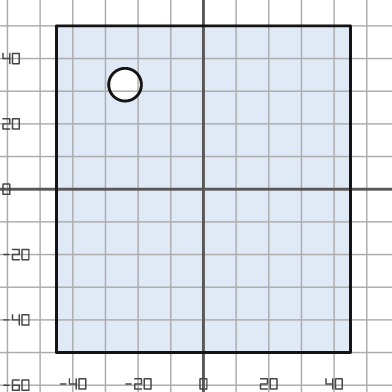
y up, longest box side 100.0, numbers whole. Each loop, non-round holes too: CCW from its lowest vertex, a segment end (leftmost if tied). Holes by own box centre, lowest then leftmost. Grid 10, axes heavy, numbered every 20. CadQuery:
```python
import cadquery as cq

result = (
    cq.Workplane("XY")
    .moveTo(-45.0, -50.0)
    .lineTo(45.0, -50.0)
    .lineTo(45.0, 50.0)
    .lineTo(-45.0, 50.0)
    .close()
    .moveTo(-24.0, 32.0)
    .circle(5.0)
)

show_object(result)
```